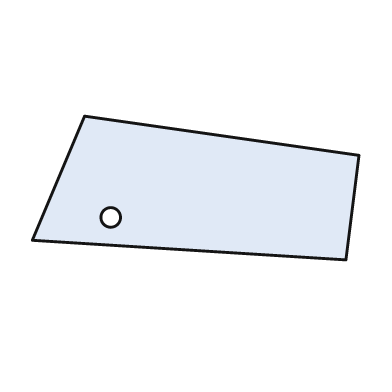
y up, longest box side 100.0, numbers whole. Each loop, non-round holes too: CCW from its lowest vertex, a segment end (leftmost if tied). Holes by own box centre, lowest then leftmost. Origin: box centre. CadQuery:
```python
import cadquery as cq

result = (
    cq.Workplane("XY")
    .moveTo(46.0, -22.0)
    .lineTo(50.0, 10.0)
    .lineTo(-34.0, 22.0)
    .lineTo(-50.0, -16.0)
    .close()
    .moveTo(-26.0, -9.0)
    .circle(3.0)
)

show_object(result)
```